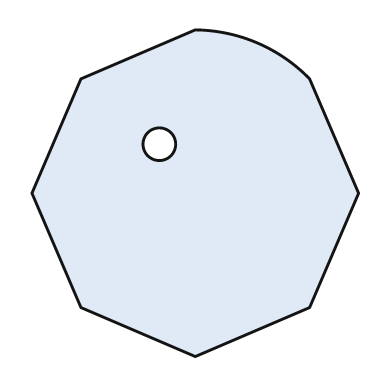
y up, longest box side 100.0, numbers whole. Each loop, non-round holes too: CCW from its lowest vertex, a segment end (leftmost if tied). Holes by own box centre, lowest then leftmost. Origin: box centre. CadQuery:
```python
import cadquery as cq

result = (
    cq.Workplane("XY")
    .moveTo(0.0, -50.0)
    .lineTo(35.0, -35.0)
    .lineTo(50.0, 0.0)
    .lineTo(35.0, 35.0)
    .threePointArc((19.0, 46.0), (0.0, 50.0))
    .lineTo(-35.0, 35.0)
    .lineTo(-50.0, 0.0)
    .lineTo(-35.0, -35.0)
    .close()
    .moveTo(-11.0, 15.0)
    .circle(5.0)
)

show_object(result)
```